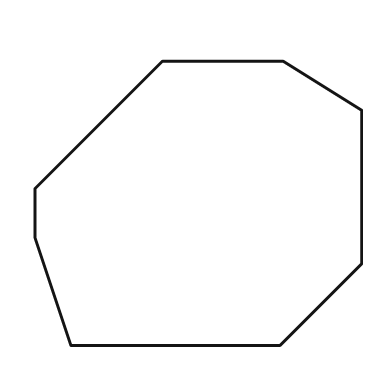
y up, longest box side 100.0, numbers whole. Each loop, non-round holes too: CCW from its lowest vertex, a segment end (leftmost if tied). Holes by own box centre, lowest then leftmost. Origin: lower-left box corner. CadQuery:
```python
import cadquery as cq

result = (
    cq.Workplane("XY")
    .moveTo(11.0, 0.0)
    .lineTo(75.0, 0.0)
    .lineTo(100.0, 25.0)
    .lineTo(100.0, 72.0)
    .lineTo(76.0, 87.0)
    .lineTo(39.0, 87.0)
    .lineTo(0.0, 48.0)
    .lineTo(0.0, 33.0)
    .close()
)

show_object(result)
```